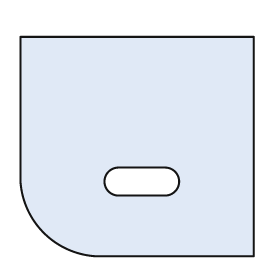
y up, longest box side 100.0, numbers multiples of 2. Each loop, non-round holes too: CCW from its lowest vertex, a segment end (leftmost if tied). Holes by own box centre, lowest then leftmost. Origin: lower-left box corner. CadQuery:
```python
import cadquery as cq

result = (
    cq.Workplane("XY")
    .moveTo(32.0, 0.0)
    .lineTo(100.0, 0.0)
    .lineTo(100.0, 94.0)
    .lineTo(0.0, 94.0)
    .lineTo(0.0, 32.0)
    .threePointArc((10.0, 10.0), (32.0, 0.0))
    .close()
    .moveTo(42.0, 26.0)
    .lineTo(62.0, 26.0)
    .threePointArc((68.0, 32.0), (62.0, 38.0))
    .lineTo(42.0, 38.0)
    .threePointArc((36.0, 32.0), (42.0, 26.0))
    .close()
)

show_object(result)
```